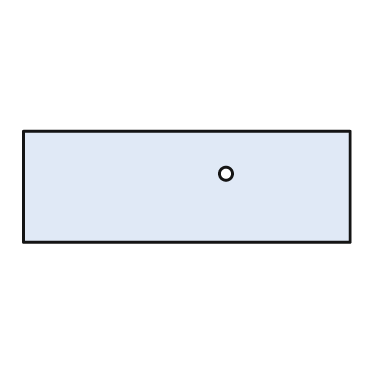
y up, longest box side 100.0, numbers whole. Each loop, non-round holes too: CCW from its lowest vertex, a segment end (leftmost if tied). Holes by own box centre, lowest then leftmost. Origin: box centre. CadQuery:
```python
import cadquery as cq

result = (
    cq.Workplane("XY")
    .moveTo(-50.0, -17.0)
    .lineTo(50.0, -17.0)
    .lineTo(50.0, 17.0)
    .lineTo(-50.0, 17.0)
    .close()
    .moveTo(12.0, 4.0)
    .circle(2.0)
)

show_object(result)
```